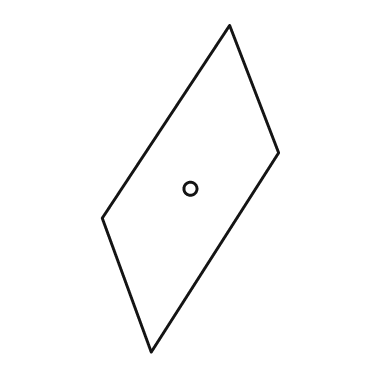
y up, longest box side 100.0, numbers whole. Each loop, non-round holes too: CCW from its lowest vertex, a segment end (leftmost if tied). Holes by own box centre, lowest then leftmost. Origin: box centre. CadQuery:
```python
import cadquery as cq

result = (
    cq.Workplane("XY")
    .moveTo(-12.0, -50.0)
    .lineTo(27.0, 11.0)
    .lineTo(12.0, 50.0)
    .lineTo(-27.0, -9.0)
    .close()
    .moveTo(0.0, 0.0)
    .circle(2.0)
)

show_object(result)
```